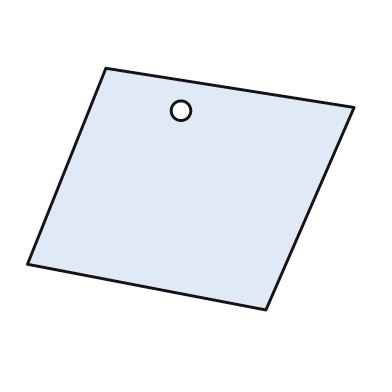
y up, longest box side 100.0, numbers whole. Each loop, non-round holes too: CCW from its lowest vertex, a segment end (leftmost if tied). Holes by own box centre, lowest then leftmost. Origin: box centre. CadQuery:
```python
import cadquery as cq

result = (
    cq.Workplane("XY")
    .moveTo(23.0, -37.0)
    .lineTo(50.0, 25.0)
    .lineTo(-26.0, 37.0)
    .lineTo(-50.0, -23.0)
    .close()
    .moveTo(-3.0, 24.0)
    .circle(3.0)
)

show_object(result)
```